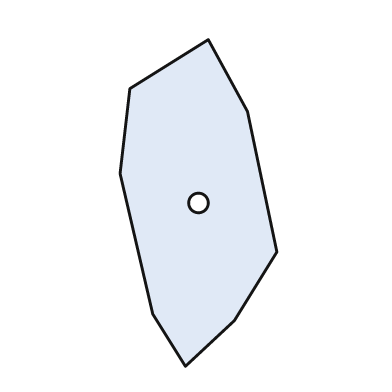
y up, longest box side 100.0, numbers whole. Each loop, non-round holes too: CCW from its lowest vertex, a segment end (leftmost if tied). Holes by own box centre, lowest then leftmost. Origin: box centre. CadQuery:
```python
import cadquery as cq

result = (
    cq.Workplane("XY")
    .moveTo(-4.0, -50.0)
    .lineTo(11.0, -36.0)
    .lineTo(24.0, -15.0)
    .lineTo(15.0, 28.0)
    .lineTo(3.0, 50.0)
    .lineTo(-21.0, 35.0)
    .lineTo(-24.0, 9.0)
    .lineTo(-14.0, -34.0)
    .close()
    .moveTo(0.0, 0.0)
    .circle(3.0)
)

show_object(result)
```